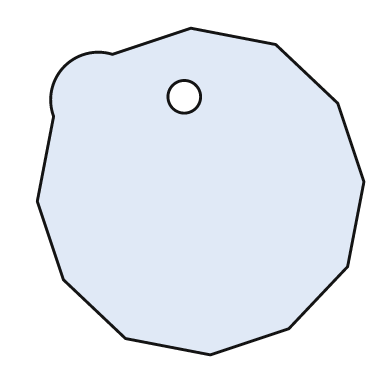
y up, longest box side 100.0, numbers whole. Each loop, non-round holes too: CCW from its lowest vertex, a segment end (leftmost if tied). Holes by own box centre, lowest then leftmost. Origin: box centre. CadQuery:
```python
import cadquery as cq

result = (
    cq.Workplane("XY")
    .moveTo(3.0, -50.0)
    .lineTo(27.0, -42.0)
    .lineTo(45.0, -23.0)
    .lineTo(50.0, 3.0)
    .lineTo(42.0, 27.0)
    .lineTo(23.0, 45.0)
    .lineTo(-3.0, 50.0)
    .lineTo(-27.0, 42.0)
    .threePointArc((-42.0, 38.0), (-45.0, 23.0))
    .lineTo(-50.0, -3.0)
    .lineTo(-42.0, -27.0)
    .lineTo(-23.0, -45.0)
    .close()
    .moveTo(-5.0, 29.0)
    .circle(5.0)
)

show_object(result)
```